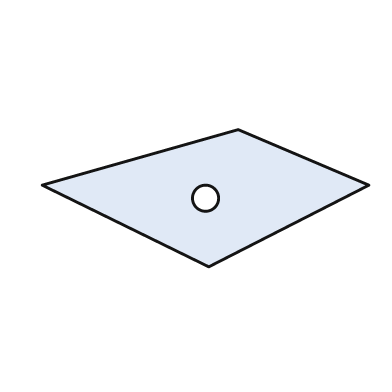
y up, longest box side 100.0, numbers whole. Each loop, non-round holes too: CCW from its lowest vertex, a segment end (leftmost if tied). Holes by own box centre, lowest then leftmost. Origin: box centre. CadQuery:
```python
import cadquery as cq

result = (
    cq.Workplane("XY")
    .moveTo(1.0, -21.0)
    .lineTo(50.0, 4.0)
    .lineTo(10.0, 21.0)
    .lineTo(-50.0, 4.0)
    .close()
    .moveTo(0.0, 0.0)
    .circle(4.0)
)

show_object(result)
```